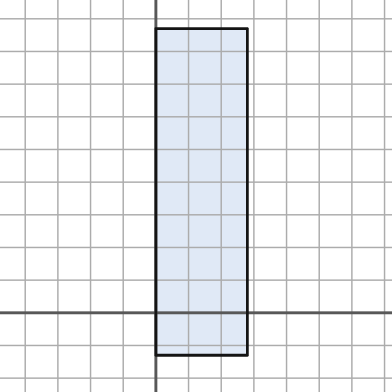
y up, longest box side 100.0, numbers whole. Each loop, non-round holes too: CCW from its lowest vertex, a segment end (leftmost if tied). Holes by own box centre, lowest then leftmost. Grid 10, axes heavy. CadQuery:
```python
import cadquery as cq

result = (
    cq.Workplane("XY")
    .moveTo(0.0, -13.0)
    .lineTo(28.0, -13.0)
    .lineTo(28.0, 87.0)
    .lineTo(0.0, 87.0)
    .close()
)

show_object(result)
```